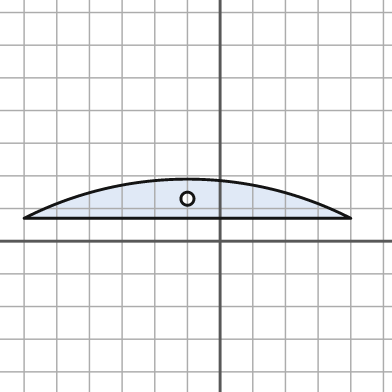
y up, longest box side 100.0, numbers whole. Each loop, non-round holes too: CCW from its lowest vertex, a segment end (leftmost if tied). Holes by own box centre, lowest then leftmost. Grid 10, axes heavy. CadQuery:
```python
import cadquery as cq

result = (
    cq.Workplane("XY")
    .moveTo(-60.0, 7.0)
    .lineTo(40.0, 7.0)
    .threePointArc((-10.0, 19.0), (-60.0, 7.0))
    .close()
    .moveTo(-10.0, 13.0)
    .circle(2.0)
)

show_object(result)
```